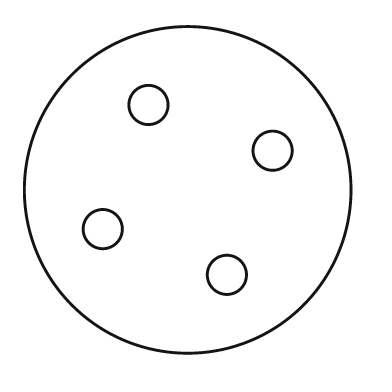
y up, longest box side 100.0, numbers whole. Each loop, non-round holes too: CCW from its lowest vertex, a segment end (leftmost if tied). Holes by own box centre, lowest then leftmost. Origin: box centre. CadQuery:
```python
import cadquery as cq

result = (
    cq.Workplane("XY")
    .moveTo(0.0, 0.0)
    .circle(50.0)
    .moveTo(12.0, -26.0)
    .circle(6.0)
    .moveTo(-26.0, -12.0)
    .circle(6.0)
    .moveTo(26.0, 12.0)
    .circle(6.0)
    .moveTo(-12.0, 26.0)
    .circle(6.0)
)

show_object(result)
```